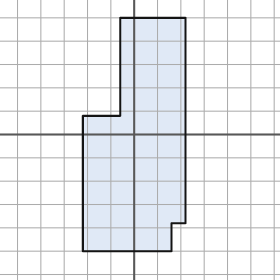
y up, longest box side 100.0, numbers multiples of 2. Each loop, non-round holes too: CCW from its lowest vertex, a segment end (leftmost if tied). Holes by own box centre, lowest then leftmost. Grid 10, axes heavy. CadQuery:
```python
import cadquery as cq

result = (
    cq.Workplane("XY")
    .moveTo(-22.0, -50.0)
    .lineTo(16.0, -50.0)
    .lineTo(16.0, -38.0)
    .lineTo(22.0, -38.0)
    .lineTo(22.0, 50.0)
    .lineTo(-6.0, 50.0)
    .lineTo(-6.0, 8.0)
    .lineTo(-22.0, 8.0)
    .close()
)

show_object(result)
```